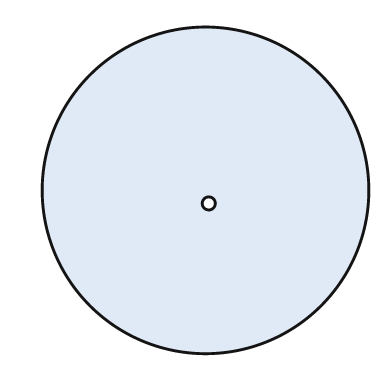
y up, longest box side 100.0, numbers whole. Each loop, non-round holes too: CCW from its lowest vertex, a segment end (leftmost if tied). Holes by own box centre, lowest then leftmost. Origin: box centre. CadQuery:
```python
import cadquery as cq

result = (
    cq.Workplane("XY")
    .moveTo(0.0, 0.0)
    .circle(50.0)
    .moveTo(1.0, -4.0)
    .circle(2.0)
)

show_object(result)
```